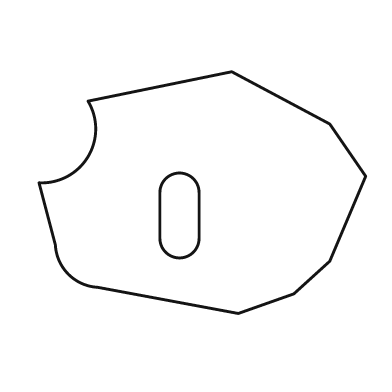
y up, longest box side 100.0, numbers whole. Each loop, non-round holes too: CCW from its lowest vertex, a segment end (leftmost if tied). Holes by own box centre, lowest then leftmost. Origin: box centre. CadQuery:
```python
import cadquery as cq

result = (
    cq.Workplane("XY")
    .moveTo(11.0, -37.0)
    .lineTo(28.0, -31.0)
    .lineTo(39.0, -21.0)
    .lineTo(50.0, 5.0)
    .lineTo(39.0, 21.0)
    .lineTo(9.0, 37.0)
    .lineTo(-35.0, 28.0)
    .threePointArc((-35.0, 11.0), (-50.0, 3.0))
    .lineTo(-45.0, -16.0)
    .threePointArc((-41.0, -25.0), (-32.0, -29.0))
    .close()
    .moveTo(-13.0, -14.0)
    .threePointArc((-7.0, -20.0), (-1.0, -14.0))
    .lineTo(-1.0, 0.0)
    .threePointArc((-7.0, 6.0), (-13.0, 0.0))
    .close()
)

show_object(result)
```